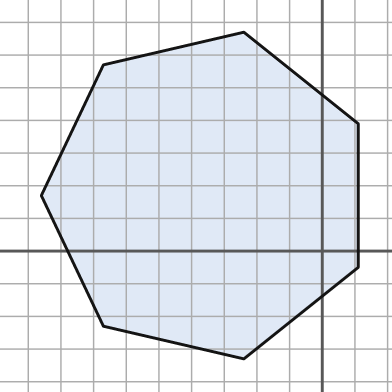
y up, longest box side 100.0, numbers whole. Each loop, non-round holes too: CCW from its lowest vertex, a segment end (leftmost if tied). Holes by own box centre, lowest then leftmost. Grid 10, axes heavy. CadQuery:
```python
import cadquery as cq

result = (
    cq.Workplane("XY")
    .moveTo(-24.0, -33.0)
    .lineTo(11.0, -5.0)
    .lineTo(11.0, 39.0)
    .lineTo(-24.0, 67.0)
    .lineTo(-67.0, 57.0)
    .lineTo(-86.0, 17.0)
    .lineTo(-67.0, -23.0)
    .close()
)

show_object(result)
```